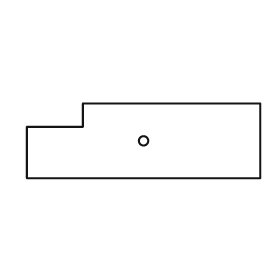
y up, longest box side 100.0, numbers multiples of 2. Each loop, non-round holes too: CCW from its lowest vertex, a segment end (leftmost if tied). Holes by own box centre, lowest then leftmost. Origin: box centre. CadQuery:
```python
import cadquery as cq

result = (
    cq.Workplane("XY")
    .moveTo(-50.0, -16.0)
    .lineTo(50.0, -16.0)
    .lineTo(50.0, 16.0)
    .lineTo(-26.0, 16.0)
    .lineTo(-26.0, 6.0)
    .lineTo(-50.0, 6.0)
    .close()
    .moveTo(0.0, 0.0)
    .circle(2.0)
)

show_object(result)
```